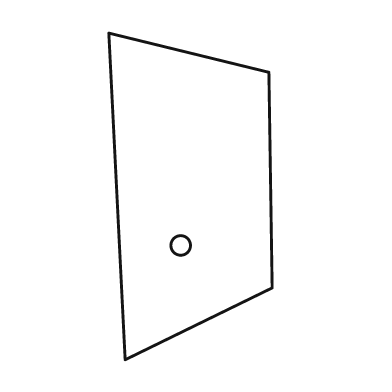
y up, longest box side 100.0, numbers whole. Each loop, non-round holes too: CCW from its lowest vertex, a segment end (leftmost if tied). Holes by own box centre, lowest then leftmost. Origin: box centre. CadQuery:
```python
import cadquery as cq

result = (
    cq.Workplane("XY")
    .moveTo(-20.0, -50.0)
    .lineTo(25.0, -28.0)
    .lineTo(24.0, 38.0)
    .lineTo(-25.0, 50.0)
    .close()
    .moveTo(-3.0, -15.0)
    .circle(3.0)
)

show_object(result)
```